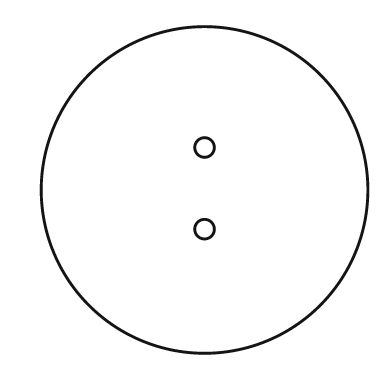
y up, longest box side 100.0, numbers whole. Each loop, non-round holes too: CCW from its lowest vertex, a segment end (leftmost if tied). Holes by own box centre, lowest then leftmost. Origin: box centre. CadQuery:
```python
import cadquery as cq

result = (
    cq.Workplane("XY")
    .moveTo(0.0, 0.0)
    .circle(50.0)
    .moveTo(0.0, -12.0)
    .circle(3.0)
    .moveTo(0.0, 13.0)
    .circle(3.0)
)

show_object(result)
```